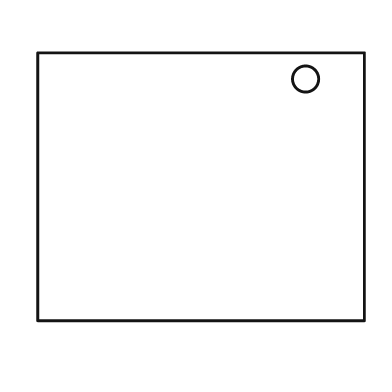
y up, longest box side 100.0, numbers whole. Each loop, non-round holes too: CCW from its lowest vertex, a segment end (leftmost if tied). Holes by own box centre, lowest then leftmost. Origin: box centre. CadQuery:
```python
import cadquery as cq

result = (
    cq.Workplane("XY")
    .moveTo(-50.0, -41.0)
    .lineTo(50.0, -41.0)
    .lineTo(50.0, 41.0)
    .lineTo(-50.0, 41.0)
    .close()
    .moveTo(32.0, 33.0)
    .circle(4.0)
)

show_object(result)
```